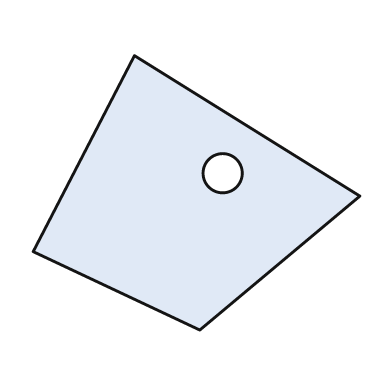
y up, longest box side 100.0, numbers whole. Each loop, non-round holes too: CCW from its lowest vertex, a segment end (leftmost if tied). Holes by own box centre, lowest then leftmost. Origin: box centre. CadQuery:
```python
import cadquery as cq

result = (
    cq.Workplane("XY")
    .moveTo(1.0, -42.0)
    .lineTo(50.0, -1.0)
    .lineTo(-19.0, 42.0)
    .lineTo(-50.0, -18.0)
    .close()
    .moveTo(8.0, 6.0)
    .circle(6.0)
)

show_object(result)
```